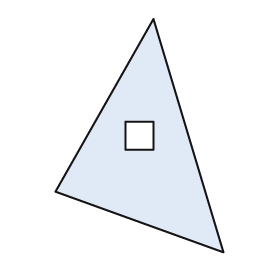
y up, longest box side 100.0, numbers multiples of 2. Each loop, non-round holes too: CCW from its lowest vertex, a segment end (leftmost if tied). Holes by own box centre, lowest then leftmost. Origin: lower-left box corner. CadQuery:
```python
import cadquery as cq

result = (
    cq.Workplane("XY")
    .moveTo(72.0, 0.0)
    .lineTo(42.0, 100.0)
    .lineTo(0.0, 26.0)
    .close()
    .moveTo(30.0, 44.0)
    .lineTo(42.0, 44.0)
    .lineTo(42.0, 56.0)
    .lineTo(30.0, 56.0)
    .close()
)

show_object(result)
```